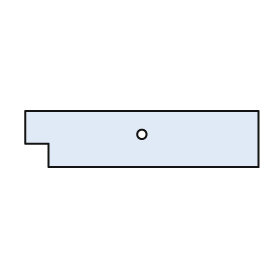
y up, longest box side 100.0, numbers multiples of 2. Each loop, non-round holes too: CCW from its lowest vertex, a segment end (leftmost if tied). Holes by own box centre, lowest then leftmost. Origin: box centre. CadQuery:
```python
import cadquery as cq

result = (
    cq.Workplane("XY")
    .moveTo(-40.0, -12.0)
    .lineTo(50.0, -12.0)
    .lineTo(50.0, 12.0)
    .lineTo(-50.0, 12.0)
    .lineTo(-50.0, -2.0)
    .lineTo(-40.0, -2.0)
    .close()
    .moveTo(0.0, 2.0)
    .circle(2.0)
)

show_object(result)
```